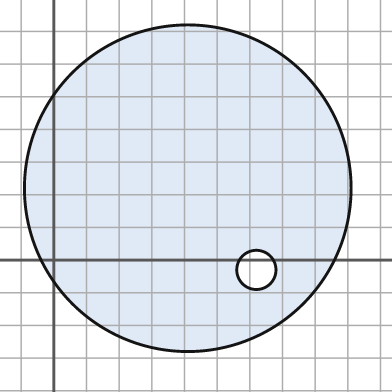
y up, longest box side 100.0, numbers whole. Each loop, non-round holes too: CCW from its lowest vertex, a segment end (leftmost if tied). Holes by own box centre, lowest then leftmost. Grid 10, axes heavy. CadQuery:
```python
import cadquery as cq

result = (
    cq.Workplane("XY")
    .moveTo(41.0, 22.0)
    .circle(50.0)
    .moveTo(62.0, -3.0)
    .circle(6.0)
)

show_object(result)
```